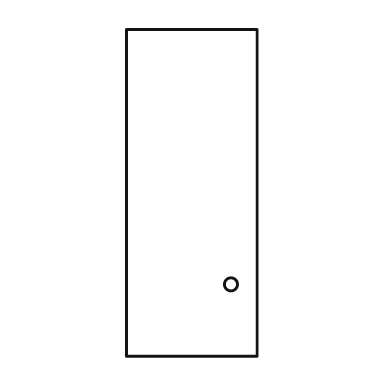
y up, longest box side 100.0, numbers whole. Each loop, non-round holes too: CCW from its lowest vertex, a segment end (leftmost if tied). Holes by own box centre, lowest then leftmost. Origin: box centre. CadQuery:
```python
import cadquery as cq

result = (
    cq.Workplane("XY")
    .moveTo(-20.0, -50.0)
    .lineTo(20.0, -50.0)
    .lineTo(20.0, 50.0)
    .lineTo(-20.0, 50.0)
    .close()
    .moveTo(12.0, -28.0)
    .circle(2.0)
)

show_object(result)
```